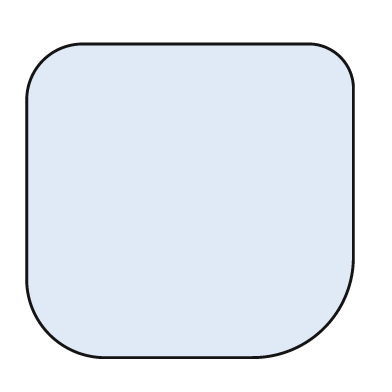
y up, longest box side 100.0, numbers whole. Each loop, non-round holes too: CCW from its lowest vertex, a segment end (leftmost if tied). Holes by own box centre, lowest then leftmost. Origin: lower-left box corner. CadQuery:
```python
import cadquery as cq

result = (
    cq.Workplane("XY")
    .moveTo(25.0, 0.0)
    .lineTo(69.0, 0.0)
    .threePointArc((91.0, 9.0), (100.0, 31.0))
    .lineTo(100.0, 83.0)
    .threePointArc((96.0, 92.0), (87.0, 96.0))
    .lineTo(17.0, 96.0)
    .threePointArc((5.0, 91.0), (0.0, 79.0))
    .lineTo(0.0, 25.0)
    .threePointArc((7.0, 7.0), (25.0, 0.0))
    .close()
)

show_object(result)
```